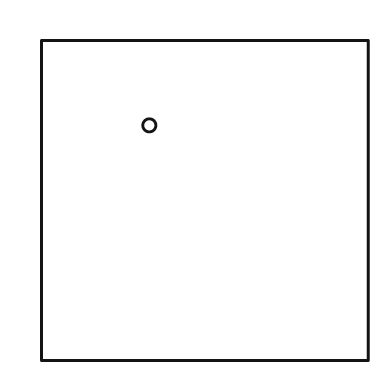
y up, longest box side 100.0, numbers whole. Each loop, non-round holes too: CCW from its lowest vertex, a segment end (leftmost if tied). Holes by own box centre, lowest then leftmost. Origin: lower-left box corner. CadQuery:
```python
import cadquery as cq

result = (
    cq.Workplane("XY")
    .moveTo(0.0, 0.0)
    .lineTo(100.0, 0.0)
    .lineTo(100.0, 98.0)
    .lineTo(0.0, 98.0)
    .close()
    .moveTo(33.0, 72.0)
    .circle(2.0)
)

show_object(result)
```